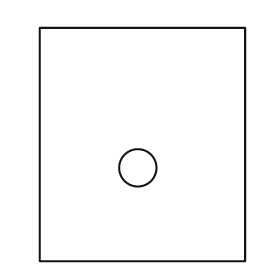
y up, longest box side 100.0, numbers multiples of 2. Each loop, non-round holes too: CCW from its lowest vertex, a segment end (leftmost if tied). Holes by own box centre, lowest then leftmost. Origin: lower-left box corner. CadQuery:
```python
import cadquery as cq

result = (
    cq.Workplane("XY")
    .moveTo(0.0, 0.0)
    .lineTo(88.0, 0.0)
    .lineTo(88.0, 100.0)
    .lineTo(0.0, 100.0)
    .close()
    .moveTo(42.0, 40.0)
    .circle(8.0)
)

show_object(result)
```